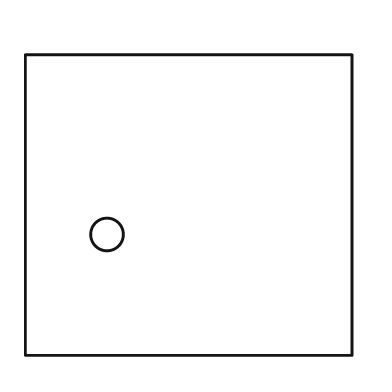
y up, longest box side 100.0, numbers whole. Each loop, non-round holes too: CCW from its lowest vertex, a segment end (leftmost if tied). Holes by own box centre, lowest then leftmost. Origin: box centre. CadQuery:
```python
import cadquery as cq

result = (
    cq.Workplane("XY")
    .moveTo(-50.0, -46.0)
    .lineTo(50.0, -46.0)
    .lineTo(50.0, 46.0)
    .lineTo(-50.0, 46.0)
    .close()
    .moveTo(-25.0, -9.0)
    .circle(5.0)
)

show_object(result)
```